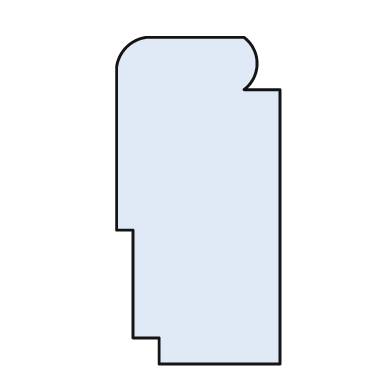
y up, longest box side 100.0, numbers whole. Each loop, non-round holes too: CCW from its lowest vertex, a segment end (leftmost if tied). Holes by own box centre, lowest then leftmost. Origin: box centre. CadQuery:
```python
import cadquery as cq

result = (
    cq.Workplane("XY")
    .moveTo(-12.0, -50.0)
    .lineTo(25.0, -50.0)
    .lineTo(25.0, 34.0)
    .lineTo(14.0, 34.0)
    .threePointArc((18.0, 42.0), (14.0, 50.0))
    .lineTo(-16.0, 50.0)
    .threePointArc((-22.0, 47.0), (-25.0, 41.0))
    .lineTo(-25.0, -9.0)
    .lineTo(-20.0, -9.0)
    .lineTo(-20.0, -42.0)
    .lineTo(-12.0, -42.0)
    .close()
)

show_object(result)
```